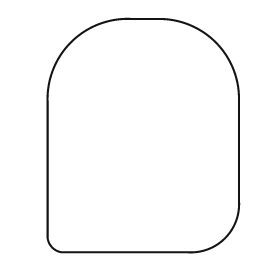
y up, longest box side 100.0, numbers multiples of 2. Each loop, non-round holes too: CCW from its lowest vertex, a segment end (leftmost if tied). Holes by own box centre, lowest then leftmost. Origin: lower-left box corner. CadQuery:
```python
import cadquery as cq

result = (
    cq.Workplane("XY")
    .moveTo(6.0, 0.0)
    .lineTo(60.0, 0.0)
    .threePointArc((76.0, 6.0), (82.0, 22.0))
    .lineTo(82.0, 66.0)
    .threePointArc((72.0, 90.0), (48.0, 100.0))
    .lineTo(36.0, 100.0)
    .threePointArc((10.0, 90.0), (0.0, 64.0))
    .lineTo(0.0, 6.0)
    .threePointArc((2.0, 2.0), (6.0, 0.0))
    .close()
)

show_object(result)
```